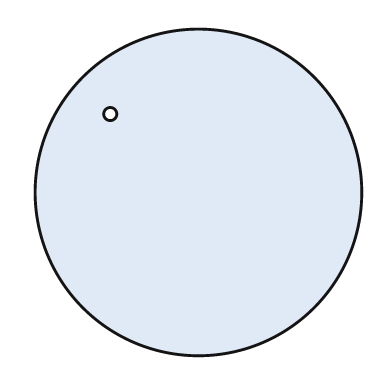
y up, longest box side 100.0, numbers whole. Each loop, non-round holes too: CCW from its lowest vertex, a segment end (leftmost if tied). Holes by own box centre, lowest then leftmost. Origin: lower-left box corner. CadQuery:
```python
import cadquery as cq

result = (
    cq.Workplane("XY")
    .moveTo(50.0, 50.0)
    .circle(50.0)
    .moveTo(23.0, 74.0)
    .circle(2.0)
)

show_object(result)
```